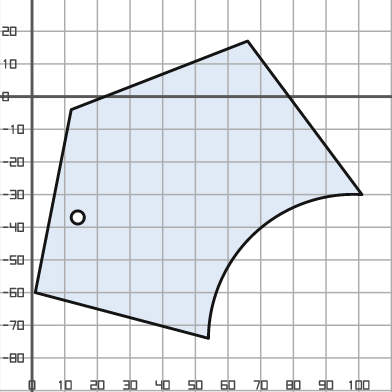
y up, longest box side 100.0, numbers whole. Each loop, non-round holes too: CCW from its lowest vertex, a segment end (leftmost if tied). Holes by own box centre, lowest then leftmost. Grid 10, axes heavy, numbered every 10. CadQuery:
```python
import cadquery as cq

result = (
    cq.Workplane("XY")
    .moveTo(54.0, -74.0)
    .threePointArc((68.0, -42.0), (101.0, -30.0))
    .lineTo(66.0, 17.0)
    .lineTo(12.0, -4.0)
    .lineTo(1.0, -60.0)
    .close()
    .moveTo(14.0, -37.0)
    .circle(2.0)
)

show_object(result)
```